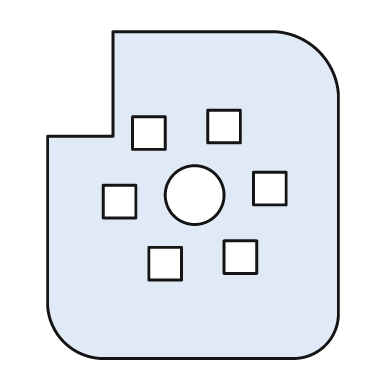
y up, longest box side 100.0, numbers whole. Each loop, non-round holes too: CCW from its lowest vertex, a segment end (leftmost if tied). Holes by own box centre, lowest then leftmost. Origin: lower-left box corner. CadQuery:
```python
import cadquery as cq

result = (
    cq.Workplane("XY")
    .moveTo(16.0, 0.0)
    .lineTo(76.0, 0.0)
    .threePointArc((85.0, 4.0), (89.0, 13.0))
    .lineTo(89.0, 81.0)
    .threePointArc((83.0, 94.0), (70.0, 100.0))
    .lineTo(20.0, 100.0)
    .lineTo(20.0, 68.0)
    .lineTo(0.0, 68.0)
    .lineTo(0.0, 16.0)
    .threePointArc((5.0, 5.0), (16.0, 0.0))
    .close()
    .moveTo(31.0, 24.0)
    .lineTo(41.0, 24.0)
    .lineTo(41.0, 34.0)
    .lineTo(31.0, 34.0)
    .close()
    .moveTo(54.0, 26.0)
    .lineTo(64.0, 26.0)
    .lineTo(64.0, 36.0)
    .lineTo(54.0, 36.0)
    .close()
    .moveTo(17.0, 43.0)
    .lineTo(27.0, 43.0)
    .lineTo(27.0, 53.0)
    .lineTo(17.0, 53.0)
    .close()
    .moveTo(45.0, 50.0)
    .circle(9.0)
    .moveTo(63.0, 47.0)
    .lineTo(73.0, 47.0)
    .lineTo(73.0, 57.0)
    .lineTo(63.0, 57.0)
    .close()
    .moveTo(26.0, 64.0)
    .lineTo(36.0, 64.0)
    .lineTo(36.0, 74.0)
    .lineTo(26.0, 74.0)
    .close()
    .moveTo(49.0, 66.0)
    .lineTo(59.0, 66.0)
    .lineTo(59.0, 76.0)
    .lineTo(49.0, 76.0)
    .close()
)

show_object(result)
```